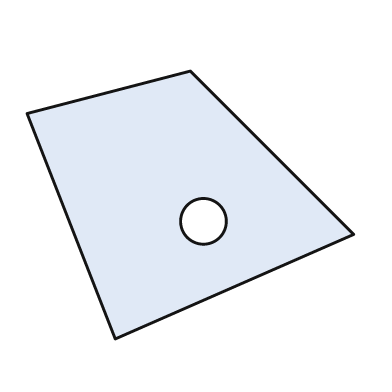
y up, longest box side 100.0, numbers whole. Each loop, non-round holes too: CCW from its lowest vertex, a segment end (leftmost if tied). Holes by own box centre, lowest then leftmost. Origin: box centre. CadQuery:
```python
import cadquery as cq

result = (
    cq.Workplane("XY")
    .moveTo(-23.0, -41.0)
    .lineTo(50.0, -9.0)
    .lineTo(0.0, 41.0)
    .lineTo(-50.0, 28.0)
    .close()
    .moveTo(4.0, -5.0)
    .circle(7.0)
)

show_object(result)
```